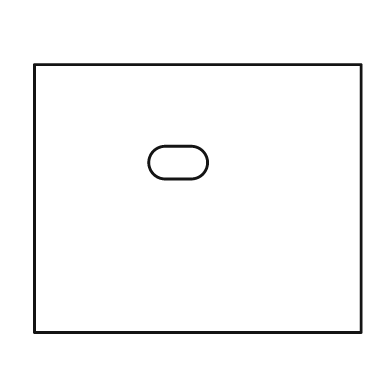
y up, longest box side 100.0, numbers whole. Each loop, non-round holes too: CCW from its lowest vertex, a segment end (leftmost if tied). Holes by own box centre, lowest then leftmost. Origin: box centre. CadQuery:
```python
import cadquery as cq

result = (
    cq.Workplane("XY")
    .moveTo(-50.0, -41.0)
    .lineTo(50.0, -41.0)
    .lineTo(50.0, 41.0)
    .lineTo(-50.0, 41.0)
    .close()
    .moveTo(-10.0, 6.0)
    .lineTo(-2.0, 6.0)
    .threePointArc((3.0, 11.0), (-2.0, 16.0))
    .lineTo(-10.0, 16.0)
    .threePointArc((-15.0, 11.0), (-10.0, 6.0))
    .close()
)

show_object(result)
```